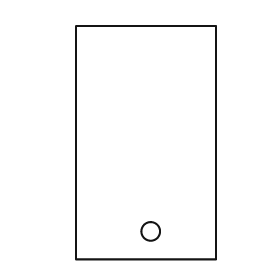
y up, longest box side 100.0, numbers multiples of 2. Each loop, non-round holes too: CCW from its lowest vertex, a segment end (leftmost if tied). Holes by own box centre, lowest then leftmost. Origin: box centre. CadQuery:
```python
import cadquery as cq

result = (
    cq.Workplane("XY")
    .moveTo(-30.0, -50.0)
    .lineTo(30.0, -50.0)
    .lineTo(30.0, 50.0)
    .lineTo(-30.0, 50.0)
    .close()
    .moveTo(2.0, -38.0)
    .circle(4.0)
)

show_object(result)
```